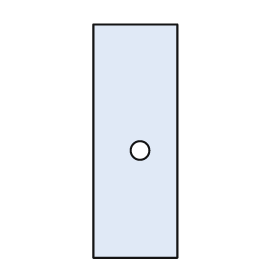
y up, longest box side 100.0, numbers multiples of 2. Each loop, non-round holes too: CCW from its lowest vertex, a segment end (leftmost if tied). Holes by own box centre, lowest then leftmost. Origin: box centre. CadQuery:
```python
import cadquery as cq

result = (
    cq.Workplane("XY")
    .moveTo(-18.0, -50.0)
    .lineTo(18.0, -50.0)
    .lineTo(18.0, 50.0)
    .lineTo(-18.0, 50.0)
    .close()
    .moveTo(2.0, -4.0)
    .circle(4.0)
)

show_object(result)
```